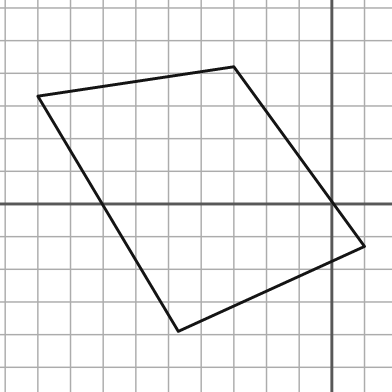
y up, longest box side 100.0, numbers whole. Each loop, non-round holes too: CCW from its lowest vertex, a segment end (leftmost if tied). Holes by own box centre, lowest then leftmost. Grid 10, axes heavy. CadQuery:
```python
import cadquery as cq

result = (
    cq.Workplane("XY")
    .moveTo(-47.0, -39.0)
    .lineTo(10.0, -13.0)
    .lineTo(-30.0, 42.0)
    .lineTo(-90.0, 33.0)
    .close()
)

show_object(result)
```